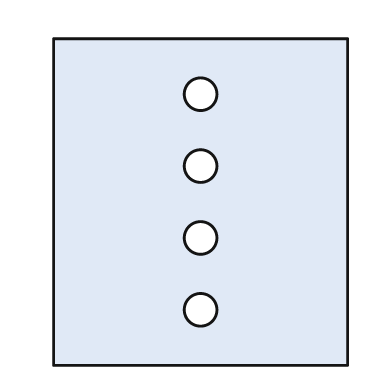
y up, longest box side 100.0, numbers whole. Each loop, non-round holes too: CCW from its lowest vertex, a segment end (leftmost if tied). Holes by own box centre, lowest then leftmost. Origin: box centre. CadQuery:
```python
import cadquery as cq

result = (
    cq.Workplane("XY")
    .moveTo(-45.0, -50.0)
    .lineTo(45.0, -50.0)
    .lineTo(45.0, 50.0)
    .lineTo(-45.0, 50.0)
    .close()
    .moveTo(0.0, -33.0)
    .circle(5.0)
    .moveTo(0.0, -11.0)
    .circle(5.0)
    .moveTo(0.0, 11.0)
    .circle(5.0)
    .moveTo(0.0, 33.0)
    .circle(5.0)
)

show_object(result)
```